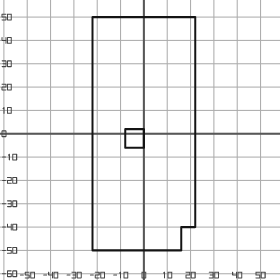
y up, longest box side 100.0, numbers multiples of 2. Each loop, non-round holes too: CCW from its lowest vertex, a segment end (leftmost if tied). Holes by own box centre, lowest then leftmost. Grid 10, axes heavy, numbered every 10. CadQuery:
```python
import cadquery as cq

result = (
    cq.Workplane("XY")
    .moveTo(-22.0, -50.0)
    .lineTo(16.0, -50.0)
    .lineTo(16.0, -40.0)
    .lineTo(22.0, -40.0)
    .lineTo(22.0, 50.0)
    .lineTo(-22.0, 50.0)
    .close()
    .moveTo(-8.0, -6.0)
    .lineTo(0.0, -6.0)
    .lineTo(0.0, 2.0)
    .lineTo(-8.0, 2.0)
    .close()
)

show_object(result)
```